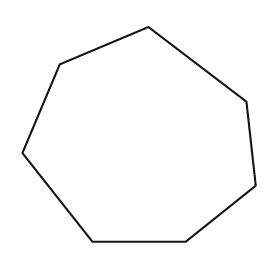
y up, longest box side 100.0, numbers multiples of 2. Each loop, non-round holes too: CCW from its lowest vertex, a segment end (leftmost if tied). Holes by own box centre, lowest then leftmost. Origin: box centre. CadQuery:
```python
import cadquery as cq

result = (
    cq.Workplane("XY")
    .moveTo(-20.0, -46.0)
    .lineTo(20.0, -46.0)
    .lineTo(50.0, -22.0)
    .lineTo(46.0, 14.0)
    .lineTo(4.0, 46.0)
    .lineTo(-34.0, 30.0)
    .lineTo(-50.0, -8.0)
    .close()
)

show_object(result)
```